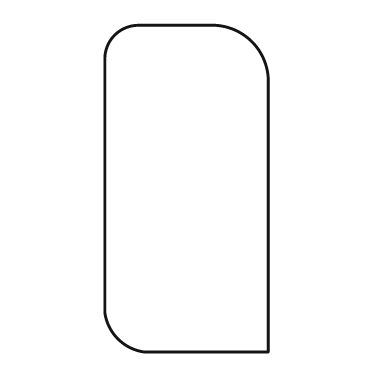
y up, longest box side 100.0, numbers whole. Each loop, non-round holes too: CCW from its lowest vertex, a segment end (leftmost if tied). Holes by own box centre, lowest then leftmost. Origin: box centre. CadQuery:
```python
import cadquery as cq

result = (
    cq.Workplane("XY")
    .moveTo(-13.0, -50.0)
    .lineTo(25.0, -50.0)
    .lineTo(25.0, 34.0)
    .threePointArc((20.0, 45.0), (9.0, 50.0))
    .lineTo(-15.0, 50.0)
    .threePointArc((-22.0, 47.0), (-25.0, 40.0))
    .lineTo(-25.0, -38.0)
    .threePointArc((-21.0, -46.0), (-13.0, -50.0))
    .close()
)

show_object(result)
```